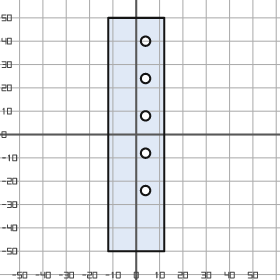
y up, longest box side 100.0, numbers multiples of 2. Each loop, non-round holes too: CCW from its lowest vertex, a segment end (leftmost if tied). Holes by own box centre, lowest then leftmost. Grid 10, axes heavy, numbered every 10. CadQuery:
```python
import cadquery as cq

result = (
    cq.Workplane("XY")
    .moveTo(-12.0, -50.0)
    .lineTo(12.0, -50.0)
    .lineTo(12.0, 50.0)
    .lineTo(-12.0, 50.0)
    .close()
    .moveTo(4.0, -24.0)
    .circle(2.0)
    .moveTo(4.0, -8.0)
    .circle(2.0)
    .moveTo(4.0, 8.0)
    .circle(2.0)
    .moveTo(4.0, 24.0)
    .circle(2.0)
    .moveTo(4.0, 40.0)
    .circle(2.0)
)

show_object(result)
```